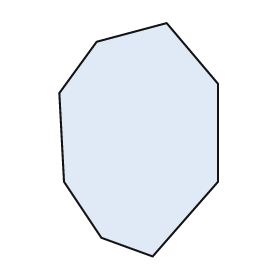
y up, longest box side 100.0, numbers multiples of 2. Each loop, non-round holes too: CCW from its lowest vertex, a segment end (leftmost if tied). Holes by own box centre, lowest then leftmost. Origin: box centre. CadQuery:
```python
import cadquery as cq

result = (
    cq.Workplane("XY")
    .moveTo(6.0, -50.0)
    .lineTo(34.0, -18.0)
    .lineTo(34.0, 24.0)
    .lineTo(12.0, 50.0)
    .lineTo(-18.0, 42.0)
    .lineTo(-34.0, 20.0)
    .lineTo(-32.0, -18.0)
    .lineTo(-16.0, -42.0)
    .close()
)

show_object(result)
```